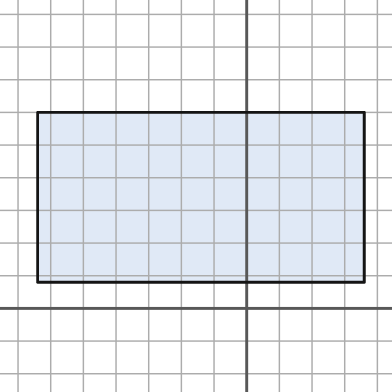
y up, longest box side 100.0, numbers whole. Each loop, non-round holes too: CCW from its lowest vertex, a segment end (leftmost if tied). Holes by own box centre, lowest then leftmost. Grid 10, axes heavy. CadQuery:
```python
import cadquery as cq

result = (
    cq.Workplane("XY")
    .moveTo(-64.0, 8.0)
    .lineTo(36.0, 8.0)
    .lineTo(36.0, 60.0)
    .lineTo(-64.0, 60.0)
    .close()
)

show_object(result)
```